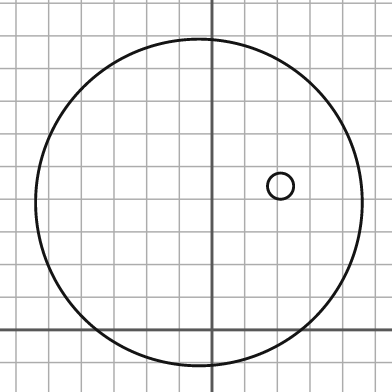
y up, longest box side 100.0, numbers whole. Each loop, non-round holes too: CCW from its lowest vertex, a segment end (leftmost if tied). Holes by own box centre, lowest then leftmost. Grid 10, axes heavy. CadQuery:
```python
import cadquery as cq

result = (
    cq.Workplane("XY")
    .moveTo(-4.0, 39.0)
    .circle(50.0)
    .moveTo(21.0, 44.0)
    .circle(4.0)
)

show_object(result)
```